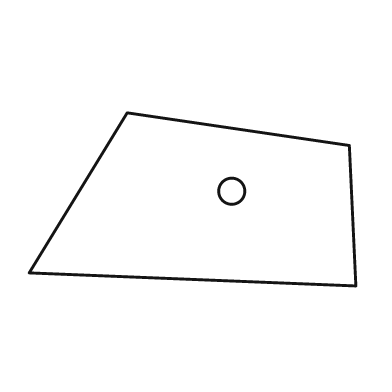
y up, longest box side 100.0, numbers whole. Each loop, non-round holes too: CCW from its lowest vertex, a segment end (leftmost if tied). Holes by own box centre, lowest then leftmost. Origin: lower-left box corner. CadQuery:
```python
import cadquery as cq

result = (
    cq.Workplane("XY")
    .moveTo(100.0, 0.0)
    .lineTo(98.0, 43.0)
    .lineTo(30.0, 53.0)
    .lineTo(0.0, 4.0)
    .close()
    .moveTo(62.0, 29.0)
    .circle(4.0)
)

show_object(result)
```